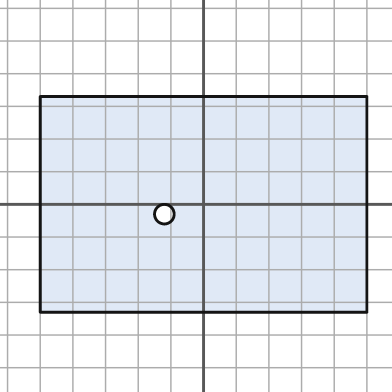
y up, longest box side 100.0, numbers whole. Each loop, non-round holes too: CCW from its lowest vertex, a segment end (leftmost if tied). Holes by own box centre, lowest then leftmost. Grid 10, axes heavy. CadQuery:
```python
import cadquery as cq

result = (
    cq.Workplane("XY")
    .moveTo(-50.0, -33.0)
    .lineTo(50.0, -33.0)
    .lineTo(50.0, 33.0)
    .lineTo(-50.0, 33.0)
    .close()
    .moveTo(-12.0, -3.0)
    .circle(3.0)
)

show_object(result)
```